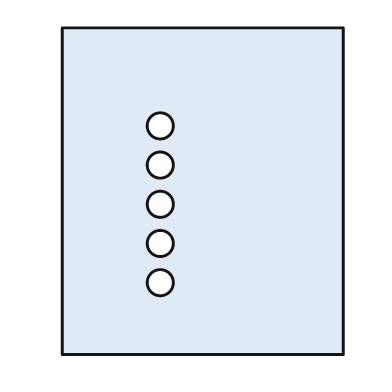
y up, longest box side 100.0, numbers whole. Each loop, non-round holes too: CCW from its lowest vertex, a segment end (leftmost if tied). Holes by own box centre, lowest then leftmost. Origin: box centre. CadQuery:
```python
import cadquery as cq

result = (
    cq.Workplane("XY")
    .moveTo(-43.0, -50.0)
    .lineTo(43.0, -50.0)
    .lineTo(43.0, 50.0)
    .lineTo(-43.0, 50.0)
    .close()
    .moveTo(-13.0, -28.0)
    .circle(4.0)
    .moveTo(-13.0, -16.0)
    .circle(4.0)
    .moveTo(-13.0, -4.0)
    .circle(4.0)
    .moveTo(-13.0, 8.0)
    .circle(4.0)
    .moveTo(-13.0, 20.0)
    .circle(4.0)
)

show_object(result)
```